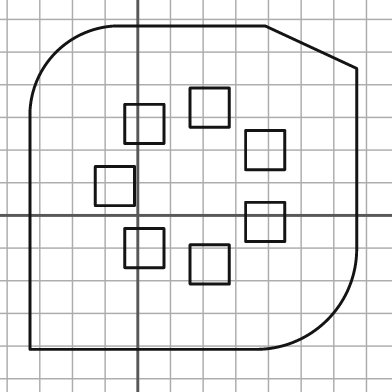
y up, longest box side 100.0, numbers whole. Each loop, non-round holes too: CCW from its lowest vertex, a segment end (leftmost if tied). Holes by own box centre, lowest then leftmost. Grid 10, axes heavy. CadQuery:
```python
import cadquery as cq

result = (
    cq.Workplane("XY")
    .moveTo(-33.0, -41.0)
    .lineTo(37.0, -41.0)
    .threePointArc((58.0, -32.0), (67.0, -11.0))
    .lineTo(67.0, 45.0)
    .lineTo(39.0, 58.0)
    .lineTo(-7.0, 58.0)
    .threePointArc((-25.0, 50.0), (-33.0, 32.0))
    .close()
    .moveTo(16.0, -21.0)
    .lineTo(28.0, -21.0)
    .lineTo(28.0, -9.0)
    .lineTo(16.0, -9.0)
    .close()
    .moveTo(-4.0, -16.0)
    .lineTo(8.0, -16.0)
    .lineTo(8.0, -4.0)
    .lineTo(-4.0, -4.0)
    .close()
    .moveTo(33.0, -8.0)
    .lineTo(45.0, -8.0)
    .lineTo(45.0, 4.0)
    .lineTo(33.0, 4.0)
    .close()
    .moveTo(-13.0, 3.0)
    .lineTo(-1.0, 3.0)
    .lineTo(-1.0, 15.0)
    .lineTo(-13.0, 15.0)
    .close()
    .moveTo(33.0, 14.0)
    .lineTo(45.0, 14.0)
    .lineTo(45.0, 26.0)
    .lineTo(33.0, 26.0)
    .close()
    .moveTo(-4.0, 22.0)
    .lineTo(8.0, 22.0)
    .lineTo(8.0, 34.0)
    .lineTo(-4.0, 34.0)
    .close()
    .moveTo(16.0, 27.0)
    .lineTo(28.0, 27.0)
    .lineTo(28.0, 39.0)
    .lineTo(16.0, 39.0)
    .close()
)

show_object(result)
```